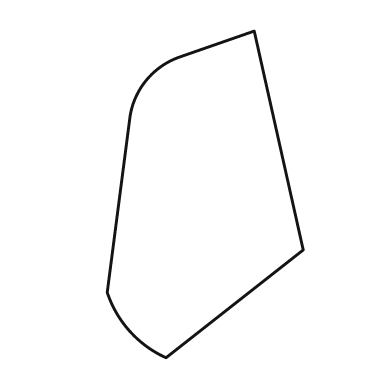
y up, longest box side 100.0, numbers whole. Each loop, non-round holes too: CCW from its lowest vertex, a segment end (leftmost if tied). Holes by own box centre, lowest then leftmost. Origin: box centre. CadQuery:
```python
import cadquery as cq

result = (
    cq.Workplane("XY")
    .moveTo(-12.0, -50.0)
    .lineTo(30.0, -17.0)
    .lineTo(15.0, 50.0)
    .lineTo(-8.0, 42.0)
    .threePointArc((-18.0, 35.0), (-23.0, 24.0))
    .lineTo(-30.0, -30.0)
    .threePointArc((-23.0, -42.0), (-12.0, -50.0))
    .close()
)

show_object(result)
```